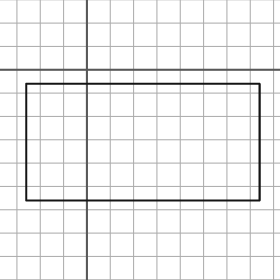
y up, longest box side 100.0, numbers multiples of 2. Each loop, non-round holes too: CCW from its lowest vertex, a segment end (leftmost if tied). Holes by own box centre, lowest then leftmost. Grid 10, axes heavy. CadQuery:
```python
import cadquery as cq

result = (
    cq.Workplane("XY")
    .moveTo(-26.0, -56.0)
    .lineTo(74.0, -56.0)
    .lineTo(74.0, -6.0)
    .lineTo(-26.0, -6.0)
    .close()
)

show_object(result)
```